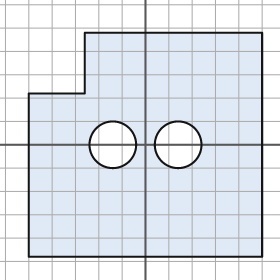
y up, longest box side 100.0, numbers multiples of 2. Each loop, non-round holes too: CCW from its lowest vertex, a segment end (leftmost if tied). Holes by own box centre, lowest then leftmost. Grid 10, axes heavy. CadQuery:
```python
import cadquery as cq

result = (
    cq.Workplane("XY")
    .moveTo(-50.0, -48.0)
    .lineTo(50.0, -48.0)
    .lineTo(50.0, 48.0)
    .lineTo(-26.0, 48.0)
    .lineTo(-26.0, 22.0)
    .lineTo(-50.0, 22.0)
    .close()
    .moveTo(-14.0, 0.0)
    .circle(10.0)
    .moveTo(14.0, 0.0)
    .circle(10.0)
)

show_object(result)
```